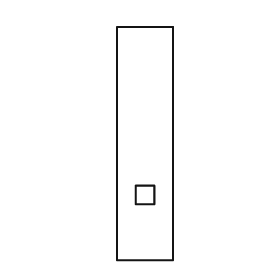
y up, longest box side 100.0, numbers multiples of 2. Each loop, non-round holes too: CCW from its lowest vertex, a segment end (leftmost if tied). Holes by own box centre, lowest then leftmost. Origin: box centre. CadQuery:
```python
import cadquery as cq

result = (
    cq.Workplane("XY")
    .moveTo(-12.0, -50.0)
    .lineTo(12.0, -50.0)
    .lineTo(12.0, 50.0)
    .lineTo(-12.0, 50.0)
    .close()
    .moveTo(-4.0, -26.0)
    .lineTo(4.0, -26.0)
    .lineTo(4.0, -18.0)
    .lineTo(-4.0, -18.0)
    .close()
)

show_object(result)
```